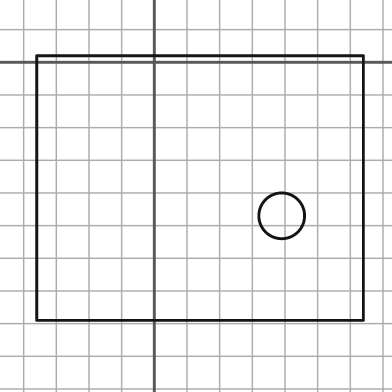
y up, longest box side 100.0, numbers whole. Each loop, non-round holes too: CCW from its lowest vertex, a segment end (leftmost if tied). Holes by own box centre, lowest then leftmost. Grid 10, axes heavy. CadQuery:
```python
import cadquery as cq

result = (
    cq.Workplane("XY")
    .moveTo(-36.0, -79.0)
    .lineTo(64.0, -79.0)
    .lineTo(64.0, 2.0)
    .lineTo(-36.0, 2.0)
    .close()
    .moveTo(39.0, -47.0)
    .circle(7.0)
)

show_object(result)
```